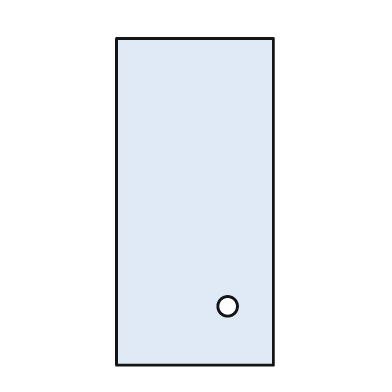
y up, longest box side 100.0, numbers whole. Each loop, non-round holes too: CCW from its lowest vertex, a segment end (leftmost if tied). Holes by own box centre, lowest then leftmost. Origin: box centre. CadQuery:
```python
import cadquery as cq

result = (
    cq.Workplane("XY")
    .moveTo(-24.0, -50.0)
    .lineTo(24.0, -50.0)
    .lineTo(24.0, 50.0)
    .lineTo(-24.0, 50.0)
    .close()
    .moveTo(10.0, -32.0)
    .circle(3.0)
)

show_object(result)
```